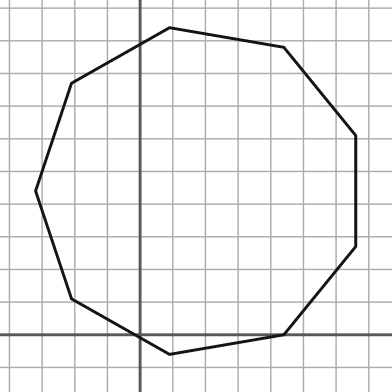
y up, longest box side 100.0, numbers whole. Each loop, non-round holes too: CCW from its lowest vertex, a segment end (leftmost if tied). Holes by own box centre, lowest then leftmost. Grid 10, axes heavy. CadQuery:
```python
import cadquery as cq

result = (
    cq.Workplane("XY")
    .moveTo(9.0, -6.0)
    .lineTo(44.0, 0.0)
    .lineTo(66.0, 27.0)
    .lineTo(66.0, 61.0)
    .lineTo(44.0, 88.0)
    .lineTo(9.0, 94.0)
    .lineTo(-21.0, 77.0)
    .lineTo(-32.0, 44.0)
    .lineTo(-21.0, 11.0)
    .close()
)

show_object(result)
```